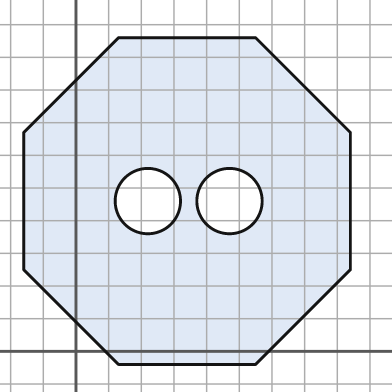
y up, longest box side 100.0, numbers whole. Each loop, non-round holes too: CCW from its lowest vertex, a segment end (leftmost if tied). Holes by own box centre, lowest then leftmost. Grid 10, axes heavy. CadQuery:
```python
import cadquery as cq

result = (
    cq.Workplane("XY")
    .moveTo(13.0, -4.0)
    .lineTo(55.0, -4.0)
    .lineTo(84.0, 25.0)
    .lineTo(84.0, 67.0)
    .lineTo(55.0, 96.0)
    .lineTo(13.0, 96.0)
    .lineTo(-16.0, 67.0)
    .lineTo(-16.0, 25.0)
    .close()
    .moveTo(22.0, 46.0)
    .circle(10.0)
    .moveTo(47.0, 46.0)
    .circle(10.0)
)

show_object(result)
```